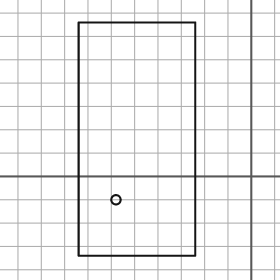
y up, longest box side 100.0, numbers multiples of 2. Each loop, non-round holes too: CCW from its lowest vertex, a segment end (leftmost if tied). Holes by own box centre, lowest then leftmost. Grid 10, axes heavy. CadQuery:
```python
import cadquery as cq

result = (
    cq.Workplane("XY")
    .moveTo(-74.0, -34.0)
    .lineTo(-24.0, -34.0)
    .lineTo(-24.0, 66.0)
    .lineTo(-74.0, 66.0)
    .close()
    .moveTo(-58.0, -10.0)
    .circle(2.0)
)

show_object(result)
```